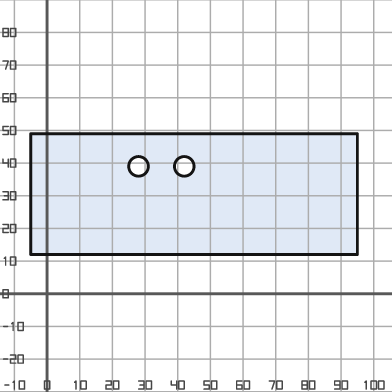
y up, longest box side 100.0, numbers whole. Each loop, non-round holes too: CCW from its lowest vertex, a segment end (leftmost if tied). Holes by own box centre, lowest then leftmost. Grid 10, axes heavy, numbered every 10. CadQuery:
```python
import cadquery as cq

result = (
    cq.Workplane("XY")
    .moveTo(-5.0, 12.0)
    .lineTo(95.0, 12.0)
    .lineTo(95.0, 49.0)
    .lineTo(-5.0, 49.0)
    .close()
    .moveTo(28.0, 39.0)
    .circle(3.0)
    .moveTo(42.0, 39.0)
    .circle(3.0)
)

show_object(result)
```